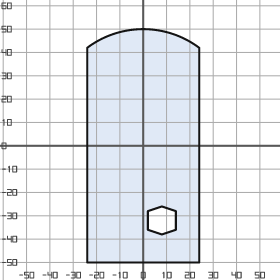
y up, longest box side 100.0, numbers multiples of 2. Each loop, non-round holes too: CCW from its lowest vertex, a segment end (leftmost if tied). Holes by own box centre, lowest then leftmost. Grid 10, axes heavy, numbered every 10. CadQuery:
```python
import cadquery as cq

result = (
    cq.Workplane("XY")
    .moveTo(-24.0, -50.0)
    .lineTo(24.0, -50.0)
    .lineTo(24.0, 42.0)
    .threePointArc((0.0, 50.0), (-24.0, 42.0))
    .close()
    .moveTo(8.0, -38.0)
    .lineTo(14.0, -36.0)
    .lineTo(14.0, -28.0)
    .lineTo(8.0, -26.0)
    .lineTo(2.0, -28.0)
    .lineTo(2.0, -36.0)
    .close()
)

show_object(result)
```